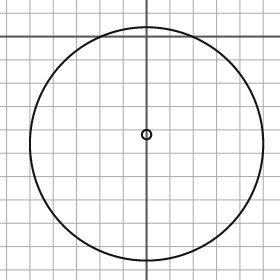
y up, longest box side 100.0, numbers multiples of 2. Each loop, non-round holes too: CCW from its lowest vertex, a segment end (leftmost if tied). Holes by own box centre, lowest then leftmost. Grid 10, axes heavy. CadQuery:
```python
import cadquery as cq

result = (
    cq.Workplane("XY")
    .moveTo(0.0, -46.0)
    .circle(50.0)
    .moveTo(0.0, -42.0)
    .circle(2.0)
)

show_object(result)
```